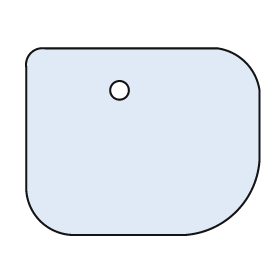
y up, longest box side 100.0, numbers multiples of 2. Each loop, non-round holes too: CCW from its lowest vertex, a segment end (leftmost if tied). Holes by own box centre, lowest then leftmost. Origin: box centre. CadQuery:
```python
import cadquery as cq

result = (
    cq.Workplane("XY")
    .moveTo(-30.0, -40.0)
    .lineTo(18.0, -40.0)
    .threePointArc((40.0, -30.0), (50.0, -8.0))
    .lineTo(50.0, 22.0)
    .threePointArc((44.0, 34.0), (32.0, 40.0))
    .lineTo(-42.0, 40.0)
    .threePointArc((-48.0, 38.0), (-50.0, 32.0))
    .lineTo(-50.0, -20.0)
    .threePointArc((-44.0, -34.0), (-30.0, -40.0))
    .close()
    .moveTo(-10.0, 22.0)
    .circle(4.0)
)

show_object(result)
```